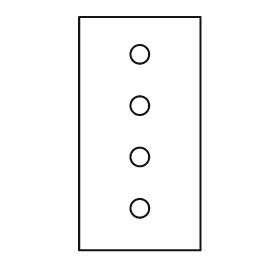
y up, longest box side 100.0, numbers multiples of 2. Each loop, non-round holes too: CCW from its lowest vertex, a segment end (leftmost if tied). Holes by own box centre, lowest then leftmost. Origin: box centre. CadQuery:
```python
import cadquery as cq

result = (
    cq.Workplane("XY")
    .moveTo(-26.0, -50.0)
    .lineTo(26.0, -50.0)
    .lineTo(26.0, 50.0)
    .lineTo(-26.0, 50.0)
    .close()
    .moveTo(0.0, -32.0)
    .circle(4.0)
    .moveTo(0.0, -10.0)
    .circle(4.0)
    .moveTo(0.0, 12.0)
    .circle(4.0)
    .moveTo(0.0, 34.0)
    .circle(4.0)
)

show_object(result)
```